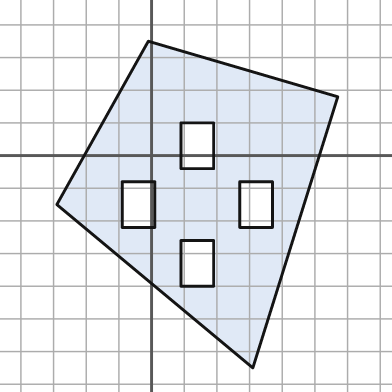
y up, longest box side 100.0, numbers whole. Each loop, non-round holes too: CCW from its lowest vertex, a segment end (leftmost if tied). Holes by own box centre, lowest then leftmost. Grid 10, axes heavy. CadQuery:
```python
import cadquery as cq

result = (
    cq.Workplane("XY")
    .moveTo(31.0, -65.0)
    .lineTo(57.0, 18.0)
    .lineTo(-1.0, 35.0)
    .lineTo(-29.0, -15.0)
    .close()
    .moveTo(9.0, -40.0)
    .lineTo(19.0, -40.0)
    .lineTo(19.0, -26.0)
    .lineTo(9.0, -26.0)
    .close()
    .moveTo(-9.0, -22.0)
    .lineTo(1.0, -22.0)
    .lineTo(1.0, -8.0)
    .lineTo(-9.0, -8.0)
    .close()
    .moveTo(27.0, -22.0)
    .lineTo(37.0, -22.0)
    .lineTo(37.0, -8.0)
    .lineTo(27.0, -8.0)
    .close()
    .moveTo(9.0, -4.0)
    .lineTo(19.0, -4.0)
    .lineTo(19.0, 10.0)
    .lineTo(9.0, 10.0)
    .close()
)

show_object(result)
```